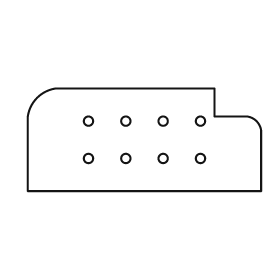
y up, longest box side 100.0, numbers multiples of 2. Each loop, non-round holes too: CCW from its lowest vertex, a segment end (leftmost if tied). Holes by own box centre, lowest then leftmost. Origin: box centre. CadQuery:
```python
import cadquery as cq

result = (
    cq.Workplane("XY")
    .moveTo(-50.0, -22.0)
    .lineTo(50.0, -22.0)
    .lineTo(50.0, 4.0)
    .threePointArc((48.0, 8.0), (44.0, 10.0))
    .lineTo(30.0, 10.0)
    .lineTo(30.0, 22.0)
    .lineTo(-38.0, 22.0)
    .threePointArc((-46.0, 18.0), (-50.0, 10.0))
    .close()
    .moveTo(-24.0, -8.0)
    .circle(2.0)
    .moveTo(-8.0, -8.0)
    .circle(2.0)
    .moveTo(8.0, -8.0)
    .circle(2.0)
    .moveTo(24.0, -8.0)
    .circle(2.0)
    .moveTo(-24.0, 8.0)
    .circle(2.0)
    .moveTo(-8.0, 8.0)
    .circle(2.0)
    .moveTo(8.0, 8.0)
    .circle(2.0)
    .moveTo(24.0, 8.0)
    .circle(2.0)
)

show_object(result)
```